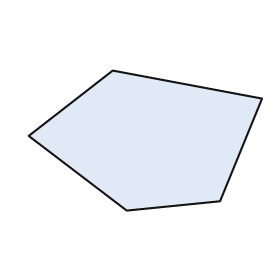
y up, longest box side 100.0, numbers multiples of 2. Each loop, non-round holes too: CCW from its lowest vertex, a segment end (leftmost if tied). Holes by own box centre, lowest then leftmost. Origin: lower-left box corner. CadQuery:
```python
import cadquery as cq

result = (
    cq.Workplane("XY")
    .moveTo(42.0, 0.0)
    .lineTo(82.0, 4.0)
    .lineTo(100.0, 48.0)
    .lineTo(36.0, 60.0)
    .lineTo(0.0, 32.0)
    .close()
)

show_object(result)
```